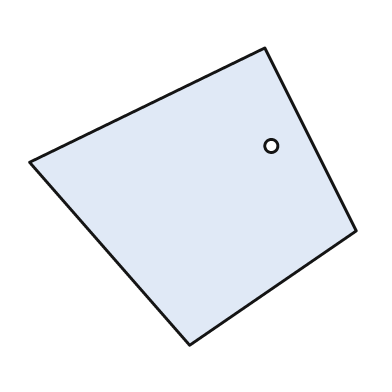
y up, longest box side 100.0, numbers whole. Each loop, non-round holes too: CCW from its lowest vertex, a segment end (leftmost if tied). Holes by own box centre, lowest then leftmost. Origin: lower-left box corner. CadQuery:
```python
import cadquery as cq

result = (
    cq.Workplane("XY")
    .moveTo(49.0, 0.0)
    .lineTo(100.0, 35.0)
    .lineTo(72.0, 91.0)
    .lineTo(0.0, 56.0)
    .close()
    .moveTo(74.0, 61.0)
    .circle(2.0)
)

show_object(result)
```